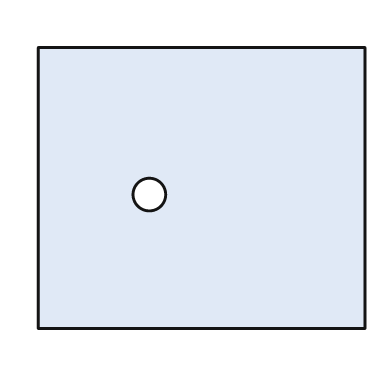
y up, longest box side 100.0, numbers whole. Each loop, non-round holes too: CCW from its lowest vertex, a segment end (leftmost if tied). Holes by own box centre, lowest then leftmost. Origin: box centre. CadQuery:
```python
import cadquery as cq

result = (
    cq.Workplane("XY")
    .moveTo(-50.0, -43.0)
    .lineTo(50.0, -43.0)
    .lineTo(50.0, 43.0)
    .lineTo(-50.0, 43.0)
    .close()
    .moveTo(-16.0, -2.0)
    .circle(5.0)
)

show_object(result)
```